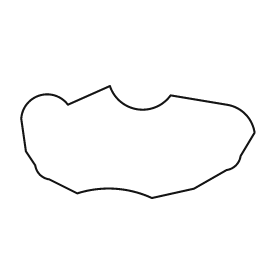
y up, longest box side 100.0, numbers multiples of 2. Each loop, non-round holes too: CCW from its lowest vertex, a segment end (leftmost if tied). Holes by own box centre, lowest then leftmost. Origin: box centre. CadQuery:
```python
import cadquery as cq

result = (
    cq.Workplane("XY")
    .moveTo(6.0, -24.0)
    .lineTo(24.0, -20.0)
    .lineTo(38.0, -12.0)
    .threePointArc((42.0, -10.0), (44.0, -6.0))
    .lineTo(50.0, 4.0)
    .threePointArc((46.0, 12.0), (38.0, 16.0))
    .lineTo(14.0, 20.0)
    .threePointArc((0.0, 14.0), (-12.0, 24.0))
    .lineTo(-30.0, 16.0)
    .threePointArc((-42.0, 20.0), (-50.0, 10.0))
    .lineTo(-48.0, -4.0)
    .lineTo(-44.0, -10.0)
    .threePointArc((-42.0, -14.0), (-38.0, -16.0))
    .lineTo(-26.0, -22.0)
    .threePointArc((-10.0, -20.0), (6.0, -24.0))
    .close()
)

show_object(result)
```